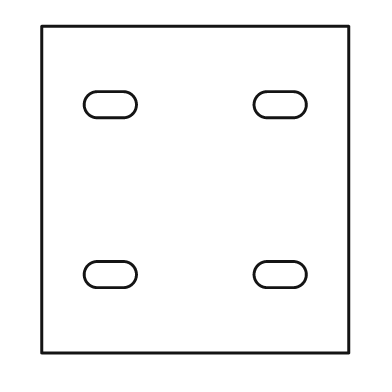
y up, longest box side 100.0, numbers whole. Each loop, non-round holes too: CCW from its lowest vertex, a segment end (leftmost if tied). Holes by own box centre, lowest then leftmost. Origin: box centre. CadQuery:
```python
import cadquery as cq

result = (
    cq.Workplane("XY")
    .moveTo(-47.0, -50.0)
    .lineTo(47.0, -50.0)
    .lineTo(47.0, 50.0)
    .lineTo(-47.0, 50.0)
    .close()
    .moveTo(-30.0, -30.0)
    .lineTo(-22.0, -30.0)
    .threePointArc((-18.0, -26.0), (-22.0, -22.0))
    .lineTo(-30.0, -22.0)
    .threePointArc((-34.0, -26.0), (-30.0, -30.0))
    .close()
    .moveTo(22.0, -30.0)
    .lineTo(30.0, -30.0)
    .threePointArc((34.0, -26.0), (30.0, -22.0))
    .lineTo(22.0, -22.0)
    .threePointArc((18.0, -26.0), (22.0, -30.0))
    .close()
    .moveTo(-30.0, 22.0)
    .lineTo(-22.0, 22.0)
    .threePointArc((-18.0, 26.0), (-22.0, 30.0))
    .lineTo(-30.0, 30.0)
    .threePointArc((-34.0, 26.0), (-30.0, 22.0))
    .close()
    .moveTo(22.0, 22.0)
    .lineTo(30.0, 22.0)
    .threePointArc((34.0, 26.0), (30.0, 30.0))
    .lineTo(22.0, 30.0)
    .threePointArc((18.0, 26.0), (22.0, 22.0))
    .close()
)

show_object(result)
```